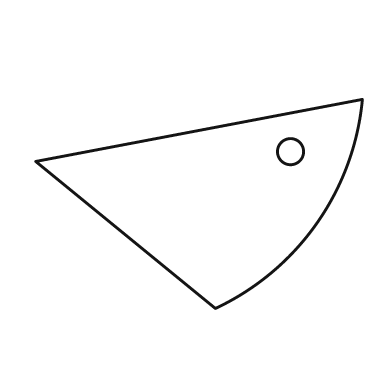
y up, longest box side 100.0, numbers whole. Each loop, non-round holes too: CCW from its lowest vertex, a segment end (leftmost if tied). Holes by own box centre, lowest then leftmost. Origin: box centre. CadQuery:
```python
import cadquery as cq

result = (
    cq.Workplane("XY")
    .moveTo(5.0, -32.0)
    .threePointArc((36.0, -6.0), (50.0, 32.0))
    .lineTo(-50.0, 13.0)
    .close()
    .moveTo(28.0, 16.0)
    .circle(4.0)
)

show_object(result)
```